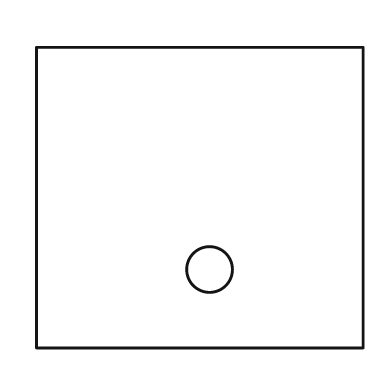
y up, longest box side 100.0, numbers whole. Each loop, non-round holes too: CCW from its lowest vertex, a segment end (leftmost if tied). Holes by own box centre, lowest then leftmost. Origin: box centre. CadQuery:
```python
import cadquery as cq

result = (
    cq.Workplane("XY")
    .moveTo(-50.0, -46.0)
    .lineTo(50.0, -46.0)
    .lineTo(50.0, 46.0)
    .lineTo(-50.0, 46.0)
    .close()
    .moveTo(3.0, -22.0)
    .circle(7.0)
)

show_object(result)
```